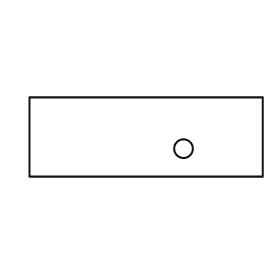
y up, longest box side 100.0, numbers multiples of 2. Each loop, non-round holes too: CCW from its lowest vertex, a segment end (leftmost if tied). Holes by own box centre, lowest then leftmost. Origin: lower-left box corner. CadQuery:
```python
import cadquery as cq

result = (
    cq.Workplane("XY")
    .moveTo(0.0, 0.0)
    .lineTo(100.0, 0.0)
    .lineTo(100.0, 34.0)
    .lineTo(0.0, 34.0)
    .close()
    .moveTo(66.0, 12.0)
    .circle(4.0)
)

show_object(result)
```